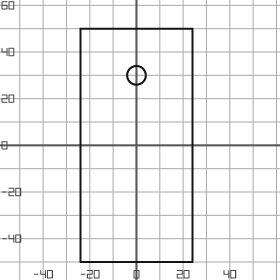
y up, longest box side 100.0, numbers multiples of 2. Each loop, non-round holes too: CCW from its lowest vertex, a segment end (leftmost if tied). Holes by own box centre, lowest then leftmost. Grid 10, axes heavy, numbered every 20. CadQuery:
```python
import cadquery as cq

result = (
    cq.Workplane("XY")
    .moveTo(-24.0, -50.0)
    .lineTo(24.0, -50.0)
    .lineTo(24.0, 50.0)
    .lineTo(-24.0, 50.0)
    .close()
    .moveTo(0.0, 30.0)
    .circle(4.0)
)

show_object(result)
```